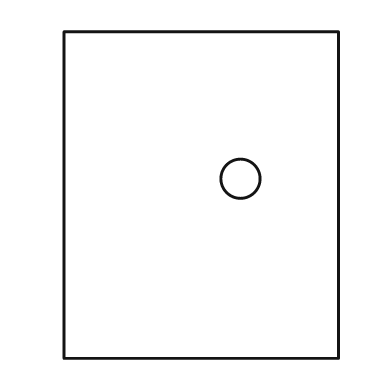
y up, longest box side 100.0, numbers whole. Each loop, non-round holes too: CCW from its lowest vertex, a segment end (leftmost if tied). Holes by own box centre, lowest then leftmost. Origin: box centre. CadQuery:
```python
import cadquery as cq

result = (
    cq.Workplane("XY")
    .moveTo(-42.0, -50.0)
    .lineTo(42.0, -50.0)
    .lineTo(42.0, 50.0)
    .lineTo(-42.0, 50.0)
    .close()
    .moveTo(12.0, 5.0)
    .circle(6.0)
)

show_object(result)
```